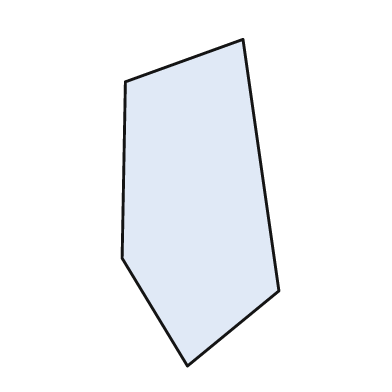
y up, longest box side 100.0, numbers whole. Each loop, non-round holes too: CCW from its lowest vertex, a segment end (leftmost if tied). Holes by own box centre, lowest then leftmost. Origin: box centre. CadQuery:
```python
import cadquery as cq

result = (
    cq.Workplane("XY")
    .moveTo(-4.0, -50.0)
    .lineTo(24.0, -27.0)
    .lineTo(13.0, 50.0)
    .lineTo(-23.0, 37.0)
    .lineTo(-24.0, -17.0)
    .close()
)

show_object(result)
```